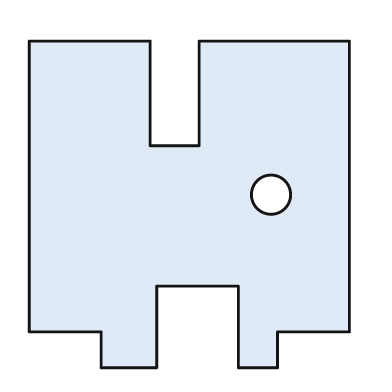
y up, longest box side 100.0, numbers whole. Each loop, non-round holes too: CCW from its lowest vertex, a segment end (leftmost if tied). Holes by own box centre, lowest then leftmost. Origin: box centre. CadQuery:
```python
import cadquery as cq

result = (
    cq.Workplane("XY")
    .moveTo(-27.0, -50.0)
    .lineTo(-10.0, -50.0)
    .lineTo(-10.0, -25.0)
    .lineTo(15.0, -25.0)
    .lineTo(15.0, -50.0)
    .lineTo(27.0, -50.0)
    .lineTo(27.0, -39.0)
    .lineTo(49.0, -39.0)
    .lineTo(49.0, 50.0)
    .lineTo(3.0, 50.0)
    .lineTo(3.0, 18.0)
    .lineTo(-12.0, 18.0)
    .lineTo(-12.0, 50.0)
    .lineTo(-49.0, 50.0)
    .lineTo(-49.0, -39.0)
    .lineTo(-27.0, -39.0)
    .close()
    .moveTo(25.0, 3.0)
    .circle(6.0)
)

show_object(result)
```